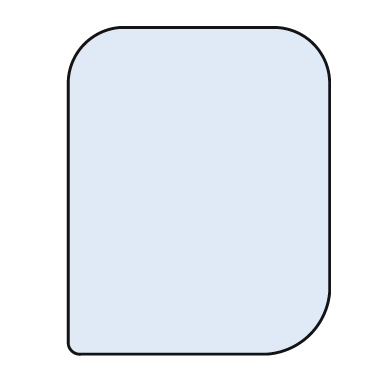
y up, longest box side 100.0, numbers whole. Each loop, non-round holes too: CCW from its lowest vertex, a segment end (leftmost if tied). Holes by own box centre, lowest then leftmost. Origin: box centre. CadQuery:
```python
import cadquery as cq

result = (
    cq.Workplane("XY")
    .moveTo(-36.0, -50.0)
    .lineTo(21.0, -50.0)
    .threePointArc((34.0, -44.0), (40.0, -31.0))
    .lineTo(40.0, 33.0)
    .threePointArc((35.0, 45.0), (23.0, 50.0))
    .lineTo(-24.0, 50.0)
    .threePointArc((-35.0, 45.0), (-40.0, 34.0))
    .lineTo(-40.0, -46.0)
    .threePointArc((-39.0, -49.0), (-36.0, -50.0))
    .close()
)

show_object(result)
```